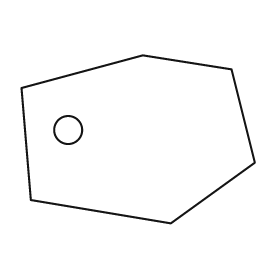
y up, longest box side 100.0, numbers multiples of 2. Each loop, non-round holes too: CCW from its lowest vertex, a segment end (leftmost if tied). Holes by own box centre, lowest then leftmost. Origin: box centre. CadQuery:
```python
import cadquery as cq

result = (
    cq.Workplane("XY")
    .moveTo(14.0, -36.0)
    .lineTo(50.0, -10.0)
    .lineTo(40.0, 30.0)
    .lineTo(2.0, 36.0)
    .lineTo(-50.0, 22.0)
    .lineTo(-46.0, -26.0)
    .close()
    .moveTo(-30.0, 4.0)
    .circle(6.0)
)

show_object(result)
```